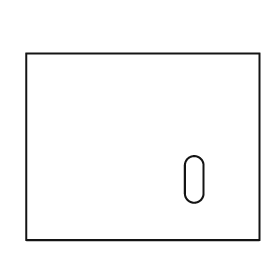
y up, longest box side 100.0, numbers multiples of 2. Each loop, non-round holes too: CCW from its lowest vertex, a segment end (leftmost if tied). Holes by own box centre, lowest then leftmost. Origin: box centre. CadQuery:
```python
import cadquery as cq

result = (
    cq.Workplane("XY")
    .moveTo(-50.0, -40.0)
    .lineTo(50.0, -40.0)
    .lineTo(50.0, 40.0)
    .lineTo(-50.0, 40.0)
    .close()
    .moveTo(18.0, -20.0)
    .threePointArc((22.0, -24.0), (26.0, -20.0))
    .lineTo(26.0, -8.0)
    .threePointArc((22.0, -4.0), (18.0, -8.0))
    .close()
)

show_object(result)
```